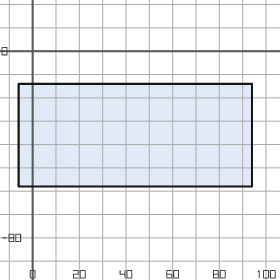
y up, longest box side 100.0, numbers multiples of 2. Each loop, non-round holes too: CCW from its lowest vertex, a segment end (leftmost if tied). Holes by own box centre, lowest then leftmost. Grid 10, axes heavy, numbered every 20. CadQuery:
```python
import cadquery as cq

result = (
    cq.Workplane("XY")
    .moveTo(-6.0, -58.0)
    .lineTo(94.0, -58.0)
    .lineTo(94.0, -14.0)
    .lineTo(-6.0, -14.0)
    .close()
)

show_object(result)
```